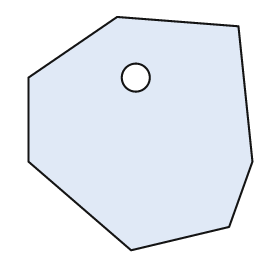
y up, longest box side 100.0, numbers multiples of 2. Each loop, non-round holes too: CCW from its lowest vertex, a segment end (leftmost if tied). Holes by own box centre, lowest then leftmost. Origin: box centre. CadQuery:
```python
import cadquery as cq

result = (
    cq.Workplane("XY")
    .moveTo(-4.0, -50.0)
    .lineTo(38.0, -40.0)
    .lineTo(48.0, -12.0)
    .lineTo(42.0, 46.0)
    .lineTo(-10.0, 50.0)
    .lineTo(-48.0, 24.0)
    .lineTo(-48.0, -12.0)
    .close()
    .moveTo(-2.0, 24.0)
    .circle(6.0)
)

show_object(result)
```